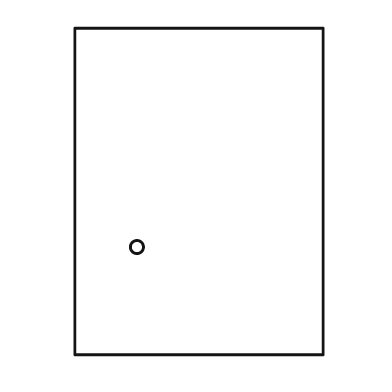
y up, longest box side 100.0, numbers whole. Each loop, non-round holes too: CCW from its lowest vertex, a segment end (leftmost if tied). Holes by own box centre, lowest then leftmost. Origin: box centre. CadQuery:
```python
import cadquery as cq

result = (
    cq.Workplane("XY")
    .moveTo(-38.0, -50.0)
    .lineTo(38.0, -50.0)
    .lineTo(38.0, 50.0)
    .lineTo(-38.0, 50.0)
    .close()
    .moveTo(-19.0, -17.0)
    .circle(2.0)
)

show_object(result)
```